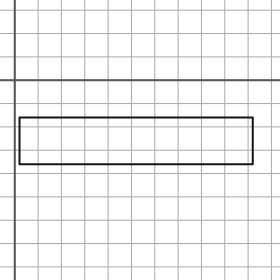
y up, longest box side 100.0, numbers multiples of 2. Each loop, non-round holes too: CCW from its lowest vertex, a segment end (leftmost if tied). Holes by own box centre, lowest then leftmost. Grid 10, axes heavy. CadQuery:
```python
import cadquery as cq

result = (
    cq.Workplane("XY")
    .moveTo(2.0, -36.0)
    .lineTo(102.0, -36.0)
    .lineTo(102.0, -16.0)
    .lineTo(2.0, -16.0)
    .close()
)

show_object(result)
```